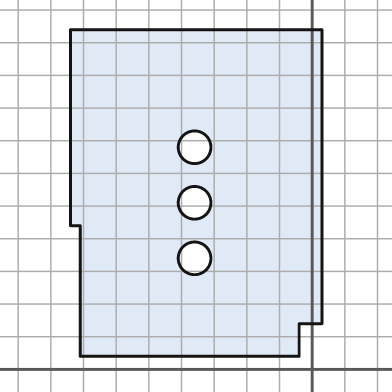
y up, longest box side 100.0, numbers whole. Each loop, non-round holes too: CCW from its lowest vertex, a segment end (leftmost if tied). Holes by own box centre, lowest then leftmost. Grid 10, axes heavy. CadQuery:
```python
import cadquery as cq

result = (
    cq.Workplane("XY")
    .moveTo(-71.0, 4.0)
    .lineTo(-4.0, 4.0)
    .lineTo(-4.0, 14.0)
    .lineTo(3.0, 14.0)
    .lineTo(3.0, 104.0)
    .lineTo(-74.0, 104.0)
    .lineTo(-74.0, 44.0)
    .lineTo(-71.0, 44.0)
    .close()
    .moveTo(-36.0, 34.0)
    .circle(5.0)
    .moveTo(-36.0, 51.0)
    .circle(5.0)
    .moveTo(-36.0, 68.0)
    .circle(5.0)
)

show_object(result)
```